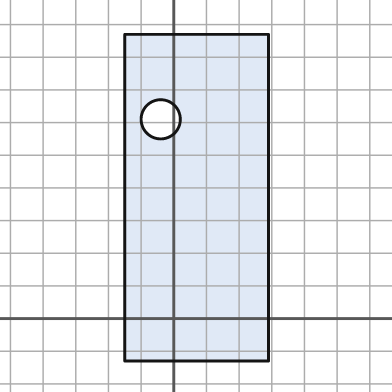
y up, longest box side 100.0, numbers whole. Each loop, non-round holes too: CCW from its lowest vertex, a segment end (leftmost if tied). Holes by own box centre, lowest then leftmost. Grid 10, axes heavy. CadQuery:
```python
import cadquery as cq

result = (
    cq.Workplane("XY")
    .moveTo(-15.0, -13.0)
    .lineTo(29.0, -13.0)
    .lineTo(29.0, 87.0)
    .lineTo(-15.0, 87.0)
    .close()
    .moveTo(-4.0, 61.0)
    .circle(6.0)
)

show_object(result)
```